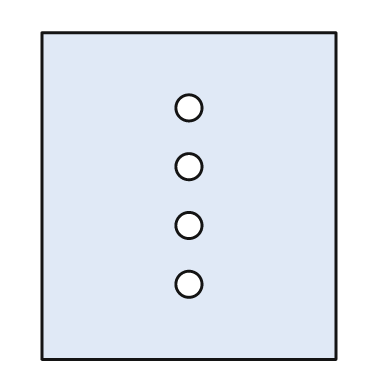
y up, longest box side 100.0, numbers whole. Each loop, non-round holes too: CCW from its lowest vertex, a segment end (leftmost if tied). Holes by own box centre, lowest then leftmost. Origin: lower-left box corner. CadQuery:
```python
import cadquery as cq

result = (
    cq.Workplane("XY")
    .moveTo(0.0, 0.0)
    .lineTo(90.0, 0.0)
    .lineTo(90.0, 100.0)
    .lineTo(0.0, 100.0)
    .close()
    .moveTo(45.0, 23.0)
    .circle(4.0)
    .moveTo(45.0, 41.0)
    .circle(4.0)
    .moveTo(45.0, 59.0)
    .circle(4.0)
    .moveTo(45.0, 77.0)
    .circle(4.0)
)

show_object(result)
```